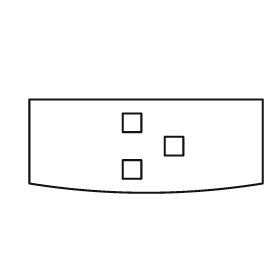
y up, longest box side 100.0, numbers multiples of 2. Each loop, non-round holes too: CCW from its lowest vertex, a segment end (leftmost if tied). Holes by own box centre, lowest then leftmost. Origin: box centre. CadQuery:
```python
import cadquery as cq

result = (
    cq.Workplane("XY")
    .moveTo(-50.0, -16.0)
    .threePointArc((0.0, -20.0), (50.0, -16.0))
    .lineTo(50.0, 20.0)
    .lineTo(-50.0, 20.0)
    .close()
    .moveTo(-10.0, -14.0)
    .lineTo(-2.0, -14.0)
    .lineTo(-2.0, -6.0)
    .lineTo(-10.0, -6.0)
    .close()
    .moveTo(8.0, -4.0)
    .lineTo(16.0, -4.0)
    .lineTo(16.0, 4.0)
    .lineTo(8.0, 4.0)
    .close()
    .moveTo(-10.0, 6.0)
    .lineTo(-2.0, 6.0)
    .lineTo(-2.0, 14.0)
    .lineTo(-10.0, 14.0)
    .close()
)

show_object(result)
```